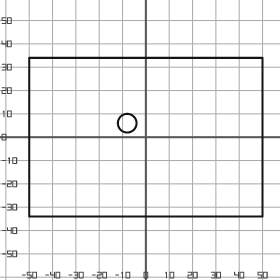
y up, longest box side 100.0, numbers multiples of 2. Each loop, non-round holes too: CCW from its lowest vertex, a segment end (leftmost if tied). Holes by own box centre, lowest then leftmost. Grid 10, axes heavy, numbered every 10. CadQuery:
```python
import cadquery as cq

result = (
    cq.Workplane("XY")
    .moveTo(-50.0, -34.0)
    .lineTo(50.0, -34.0)
    .lineTo(50.0, 34.0)
    .lineTo(-50.0, 34.0)
    .close()
    .moveTo(-8.0, 6.0)
    .circle(4.0)
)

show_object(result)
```